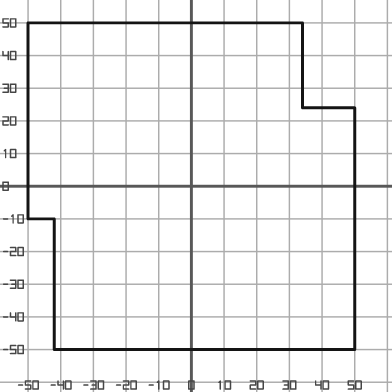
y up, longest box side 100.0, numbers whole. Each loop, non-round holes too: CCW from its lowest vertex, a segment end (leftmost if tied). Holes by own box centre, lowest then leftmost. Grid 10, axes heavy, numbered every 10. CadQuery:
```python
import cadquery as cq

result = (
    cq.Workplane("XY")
    .moveTo(-42.0, -50.0)
    .lineTo(50.0, -50.0)
    .lineTo(50.0, 24.0)
    .lineTo(34.0, 24.0)
    .lineTo(34.0, 50.0)
    .lineTo(-50.0, 50.0)
    .lineTo(-50.0, -10.0)
    .lineTo(-42.0, -10.0)
    .close()
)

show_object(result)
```